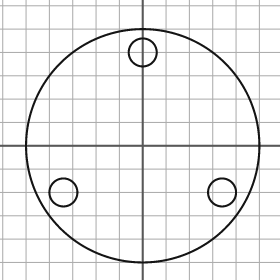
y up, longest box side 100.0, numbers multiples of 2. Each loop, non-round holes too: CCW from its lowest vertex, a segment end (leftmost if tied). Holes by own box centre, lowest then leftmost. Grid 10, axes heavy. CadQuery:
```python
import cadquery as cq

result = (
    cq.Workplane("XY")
    .moveTo(0.0, 0.0)
    .circle(50.0)
    .moveTo(-34.0, -20.0)
    .circle(6.0)
    .moveTo(34.0, -20.0)
    .circle(6.0)
    .moveTo(0.0, 40.0)
    .circle(6.0)
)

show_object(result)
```